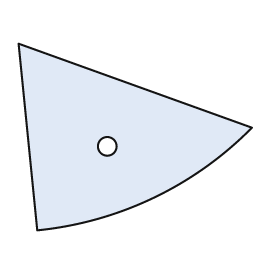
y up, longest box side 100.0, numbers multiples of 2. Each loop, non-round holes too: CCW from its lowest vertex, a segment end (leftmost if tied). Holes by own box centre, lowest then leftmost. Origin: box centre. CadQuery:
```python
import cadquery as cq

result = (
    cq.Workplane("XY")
    .moveTo(-42.0, -40.0)
    .threePointArc((8.0, -26.0), (50.0, 4.0))
    .lineTo(-50.0, 40.0)
    .close()
    .moveTo(-12.0, -4.0)
    .circle(4.0)
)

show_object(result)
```